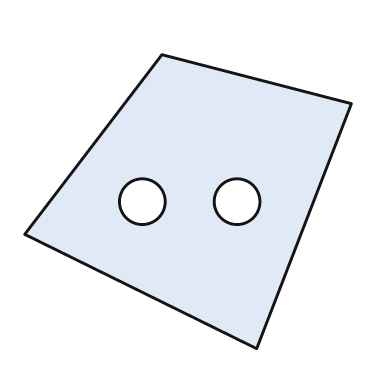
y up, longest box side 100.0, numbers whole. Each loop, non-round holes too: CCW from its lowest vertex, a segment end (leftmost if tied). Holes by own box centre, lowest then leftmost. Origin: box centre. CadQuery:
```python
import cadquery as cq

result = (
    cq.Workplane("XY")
    .moveTo(21.0, -45.0)
    .lineTo(50.0, 30.0)
    .lineTo(-8.0, 45.0)
    .lineTo(-50.0, -10.0)
    .close()
    .moveTo(-14.0, 0.0)
    .circle(7.0)
    .moveTo(15.0, 0.0)
    .circle(7.0)
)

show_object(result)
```